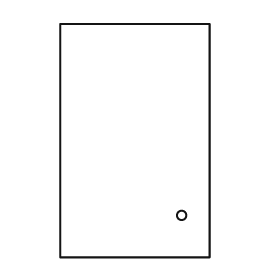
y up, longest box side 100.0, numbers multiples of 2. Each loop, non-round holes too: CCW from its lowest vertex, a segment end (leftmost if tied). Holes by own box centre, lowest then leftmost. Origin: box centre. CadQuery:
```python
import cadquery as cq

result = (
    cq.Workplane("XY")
    .moveTo(-32.0, -50.0)
    .lineTo(32.0, -50.0)
    .lineTo(32.0, 50.0)
    .lineTo(-32.0, 50.0)
    .close()
    .moveTo(20.0, -32.0)
    .circle(2.0)
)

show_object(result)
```